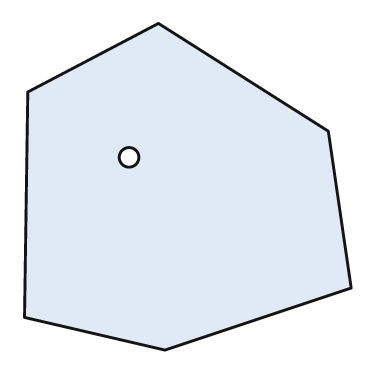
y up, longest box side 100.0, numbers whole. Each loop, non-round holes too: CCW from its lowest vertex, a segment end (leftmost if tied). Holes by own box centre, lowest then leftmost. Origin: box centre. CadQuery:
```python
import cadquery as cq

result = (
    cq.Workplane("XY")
    .moveTo(-7.0, -50.0)
    .lineTo(50.0, -31.0)
    .lineTo(43.0, 17.0)
    .lineTo(-9.0, 50.0)
    .lineTo(-49.0, 29.0)
    .lineTo(-50.0, -40.0)
    .close()
    .moveTo(-18.0, 9.0)
    .circle(3.0)
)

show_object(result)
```